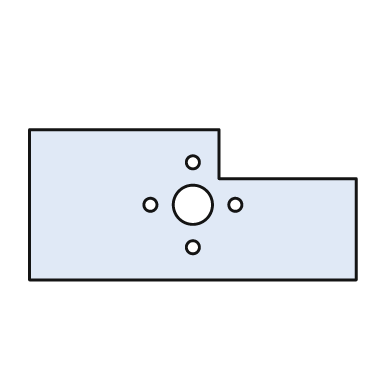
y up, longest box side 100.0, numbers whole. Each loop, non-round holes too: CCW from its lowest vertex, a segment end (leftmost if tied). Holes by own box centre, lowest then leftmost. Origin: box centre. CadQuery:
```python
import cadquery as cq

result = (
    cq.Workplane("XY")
    .moveTo(-50.0, -23.0)
    .lineTo(50.0, -23.0)
    .lineTo(50.0, 8.0)
    .lineTo(8.0, 8.0)
    .lineTo(8.0, 23.0)
    .lineTo(-50.0, 23.0)
    .close()
    .moveTo(0.0, -13.0)
    .circle(2.0)
    .moveTo(-13.0, 0.0)
    .circle(2.0)
    .moveTo(0.0, 0.0)
    .circle(6.0)
    .moveTo(13.0, 0.0)
    .circle(2.0)
    .moveTo(0.0, 13.0)
    .circle(2.0)
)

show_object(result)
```